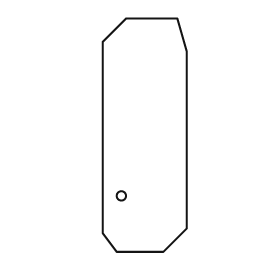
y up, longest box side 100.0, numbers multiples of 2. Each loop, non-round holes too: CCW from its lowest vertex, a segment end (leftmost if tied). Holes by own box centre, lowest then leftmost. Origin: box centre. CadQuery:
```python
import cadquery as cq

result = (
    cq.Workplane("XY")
    .moveTo(-12.0, -50.0)
    .lineTo(8.0, -50.0)
    .lineTo(18.0, -40.0)
    .lineTo(18.0, 36.0)
    .lineTo(14.0, 50.0)
    .lineTo(-8.0, 50.0)
    .lineTo(-18.0, 40.0)
    .lineTo(-18.0, -42.0)
    .close()
    .moveTo(-10.0, -26.0)
    .circle(2.0)
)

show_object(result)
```